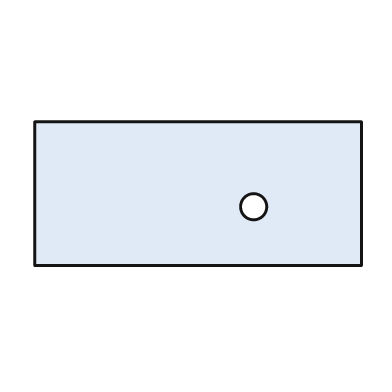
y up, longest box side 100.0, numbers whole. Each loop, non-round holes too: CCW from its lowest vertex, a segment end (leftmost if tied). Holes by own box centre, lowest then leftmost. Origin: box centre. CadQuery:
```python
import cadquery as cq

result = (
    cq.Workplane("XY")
    .moveTo(-50.0, -22.0)
    .lineTo(50.0, -22.0)
    .lineTo(50.0, 22.0)
    .lineTo(-50.0, 22.0)
    .close()
    .moveTo(17.0, -4.0)
    .circle(4.0)
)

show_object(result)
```